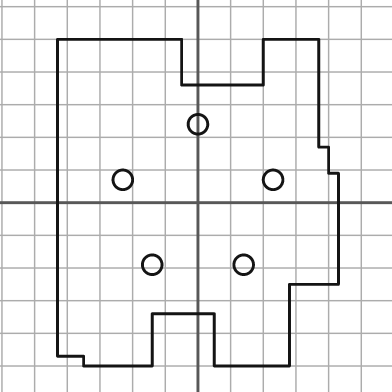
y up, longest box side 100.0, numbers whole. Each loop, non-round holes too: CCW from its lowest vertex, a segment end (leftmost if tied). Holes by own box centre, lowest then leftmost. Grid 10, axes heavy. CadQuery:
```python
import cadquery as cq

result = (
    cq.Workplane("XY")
    .moveTo(-35.0, -50.0)
    .lineTo(-14.0, -50.0)
    .lineTo(-14.0, -34.0)
    .lineTo(5.0, -34.0)
    .lineTo(5.0, -50.0)
    .lineTo(28.0, -50.0)
    .lineTo(28.0, -25.0)
    .lineTo(43.0, -25.0)
    .lineTo(43.0, 9.0)
    .lineTo(40.0, 9.0)
    .lineTo(40.0, 17.0)
    .lineTo(37.0, 17.0)
    .lineTo(37.0, 50.0)
    .lineTo(20.0, 50.0)
    .lineTo(20.0, 36.0)
    .lineTo(-5.0, 36.0)
    .lineTo(-5.0, 50.0)
    .lineTo(-43.0, 50.0)
    .lineTo(-43.0, -47.0)
    .lineTo(-35.0, -47.0)
    .close()
    .moveTo(-14.0, -19.0)
    .circle(3.0)
    .moveTo(14.0, -19.0)
    .circle(3.0)
    .moveTo(-23.0, 7.0)
    .circle(3.0)
    .moveTo(23.0, 7.0)
    .circle(3.0)
    .moveTo(0.0, 24.0)
    .circle(3.0)
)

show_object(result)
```